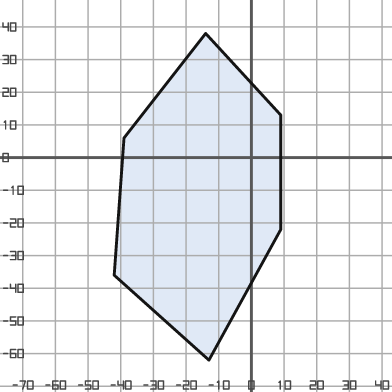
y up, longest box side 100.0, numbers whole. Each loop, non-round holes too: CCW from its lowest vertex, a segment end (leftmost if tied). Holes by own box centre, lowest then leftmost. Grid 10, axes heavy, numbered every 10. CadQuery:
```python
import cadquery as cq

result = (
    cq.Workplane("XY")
    .moveTo(-13.0, -62.0)
    .lineTo(9.0, -22.0)
    .lineTo(9.0, 13.0)
    .lineTo(-14.0, 38.0)
    .lineTo(-39.0, 6.0)
    .lineTo(-42.0, -36.0)
    .close()
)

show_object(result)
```